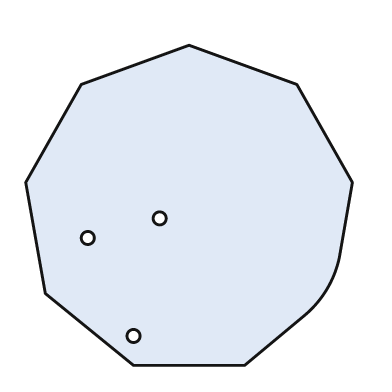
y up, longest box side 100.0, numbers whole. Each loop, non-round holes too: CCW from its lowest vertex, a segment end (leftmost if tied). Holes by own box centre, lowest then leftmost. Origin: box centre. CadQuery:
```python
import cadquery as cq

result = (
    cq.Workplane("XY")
    .moveTo(-17.0, -49.0)
    .lineTo(17.0, -49.0)
    .lineTo(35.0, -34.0)
    .threePointArc((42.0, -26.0), (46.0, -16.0))
    .lineTo(50.0, 7.0)
    .lineTo(33.0, 37.0)
    .lineTo(0.0, 49.0)
    .lineTo(-33.0, 37.0)
    .lineTo(-50.0, 7.0)
    .lineTo(-44.0, -27.0)
    .close()
    .moveTo(-17.0, -40.0)
    .circle(2.0)
    .moveTo(-31.0, -10.0)
    .circle(2.0)
    .moveTo(-9.0, -4.0)
    .circle(2.0)
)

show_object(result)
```